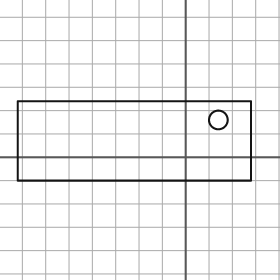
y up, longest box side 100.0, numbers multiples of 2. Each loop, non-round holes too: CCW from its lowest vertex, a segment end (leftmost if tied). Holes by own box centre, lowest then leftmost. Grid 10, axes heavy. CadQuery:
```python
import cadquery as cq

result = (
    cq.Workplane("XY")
    .moveTo(-72.0, -10.0)
    .lineTo(28.0, -10.0)
    .lineTo(28.0, 24.0)
    .lineTo(-72.0, 24.0)
    .close()
    .moveTo(14.0, 16.0)
    .circle(4.0)
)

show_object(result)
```